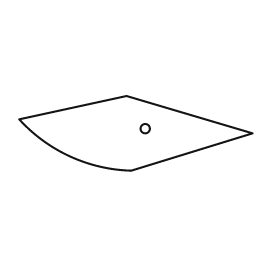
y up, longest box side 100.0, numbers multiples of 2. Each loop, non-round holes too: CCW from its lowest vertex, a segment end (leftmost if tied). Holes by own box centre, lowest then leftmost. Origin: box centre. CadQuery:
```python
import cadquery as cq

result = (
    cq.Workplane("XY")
    .moveTo(-2.0, -16.0)
    .lineTo(50.0, 0.0)
    .lineTo(-4.0, 16.0)
    .lineTo(-50.0, 6.0)
    .threePointArc((-28.0, -10.0), (-2.0, -16.0))
    .close()
    .moveTo(4.0, 2.0)
    .circle(2.0)
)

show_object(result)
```